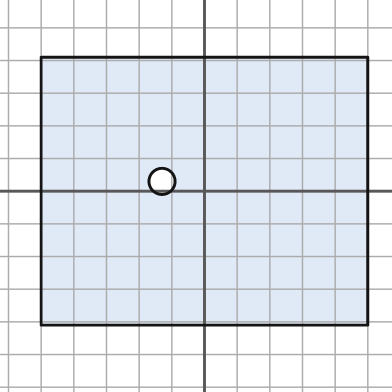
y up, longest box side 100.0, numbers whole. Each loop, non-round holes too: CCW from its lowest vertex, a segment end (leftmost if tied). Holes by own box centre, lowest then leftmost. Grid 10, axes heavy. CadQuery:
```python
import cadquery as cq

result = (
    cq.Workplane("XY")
    .moveTo(-50.0, -41.0)
    .lineTo(50.0, -41.0)
    .lineTo(50.0, 41.0)
    .lineTo(-50.0, 41.0)
    .close()
    .moveTo(-13.0, 3.0)
    .circle(4.0)
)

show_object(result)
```